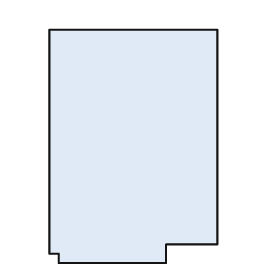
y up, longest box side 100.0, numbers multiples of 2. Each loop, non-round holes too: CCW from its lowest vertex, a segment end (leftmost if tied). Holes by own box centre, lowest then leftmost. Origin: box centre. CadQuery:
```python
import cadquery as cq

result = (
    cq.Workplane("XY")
    .moveTo(-32.0, -50.0)
    .lineTo(14.0, -50.0)
    .lineTo(14.0, -42.0)
    .lineTo(36.0, -42.0)
    .lineTo(36.0, 50.0)
    .lineTo(-36.0, 50.0)
    .lineTo(-36.0, -46.0)
    .lineTo(-32.0, -46.0)
    .close()
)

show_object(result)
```